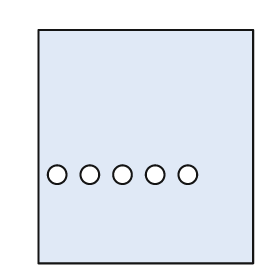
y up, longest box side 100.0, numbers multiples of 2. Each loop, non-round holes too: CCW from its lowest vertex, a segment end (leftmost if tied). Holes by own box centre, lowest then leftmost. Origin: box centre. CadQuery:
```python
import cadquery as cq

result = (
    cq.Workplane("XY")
    .moveTo(-46.0, -50.0)
    .lineTo(46.0, -50.0)
    .lineTo(46.0, 50.0)
    .lineTo(-46.0, 50.0)
    .close()
    .moveTo(-38.0, -12.0)
    .circle(4.0)
    .moveTo(-24.0, -12.0)
    .circle(4.0)
    .moveTo(-10.0, -12.0)
    .circle(4.0)
    .moveTo(4.0, -12.0)
    .circle(4.0)
    .moveTo(18.0, -12.0)
    .circle(4.0)
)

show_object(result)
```